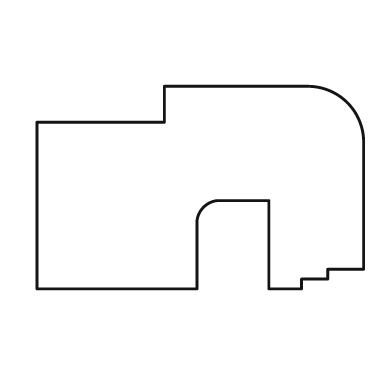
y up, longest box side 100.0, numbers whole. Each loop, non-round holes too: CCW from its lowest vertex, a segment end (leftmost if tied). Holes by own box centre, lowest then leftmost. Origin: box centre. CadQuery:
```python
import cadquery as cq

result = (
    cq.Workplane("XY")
    .moveTo(-50.0, -31.0)
    .lineTo(-1.0, -31.0)
    .lineTo(-1.0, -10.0)
    .threePointArc((1.0, -6.0), (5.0, -4.0))
    .lineTo(21.0, -4.0)
    .lineTo(21.0, -31.0)
    .lineTo(31.0, -31.0)
    .lineTo(31.0, -28.0)
    .lineTo(39.0, -28.0)
    .lineTo(39.0, -25.0)
    .lineTo(50.0, -25.0)
    .lineTo(50.0, 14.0)
    .threePointArc((45.0, 26.0), (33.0, 31.0))
    .lineTo(-11.0, 31.0)
    .lineTo(-11.0, 20.0)
    .lineTo(-50.0, 20.0)
    .close()
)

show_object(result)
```